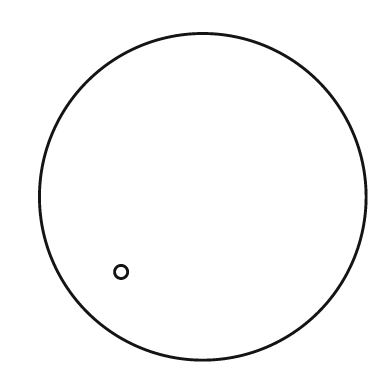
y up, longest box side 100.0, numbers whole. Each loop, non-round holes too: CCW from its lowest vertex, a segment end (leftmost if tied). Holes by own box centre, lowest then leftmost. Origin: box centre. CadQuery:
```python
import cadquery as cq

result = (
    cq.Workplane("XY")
    .moveTo(0.0, 0.0)
    .circle(50.0)
    .moveTo(-25.0, -23.0)
    .circle(2.0)
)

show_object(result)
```